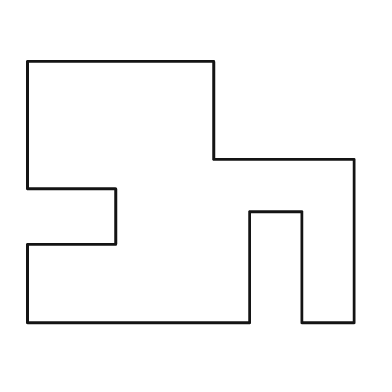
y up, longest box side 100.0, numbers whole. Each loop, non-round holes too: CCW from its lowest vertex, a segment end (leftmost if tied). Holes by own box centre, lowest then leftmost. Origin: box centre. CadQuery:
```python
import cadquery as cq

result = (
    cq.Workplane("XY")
    .moveTo(-50.0, -40.0)
    .lineTo(18.0, -40.0)
    .lineTo(18.0, -6.0)
    .lineTo(34.0, -6.0)
    .lineTo(34.0, -40.0)
    .lineTo(50.0, -40.0)
    .lineTo(50.0, 10.0)
    .lineTo(7.0, 10.0)
    .lineTo(7.0, 40.0)
    .lineTo(-50.0, 40.0)
    .lineTo(-50.0, 1.0)
    .lineTo(-23.0, 1.0)
    .lineTo(-23.0, -16.0)
    .lineTo(-50.0, -16.0)
    .close()
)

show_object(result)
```